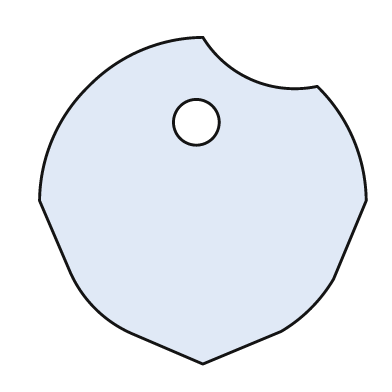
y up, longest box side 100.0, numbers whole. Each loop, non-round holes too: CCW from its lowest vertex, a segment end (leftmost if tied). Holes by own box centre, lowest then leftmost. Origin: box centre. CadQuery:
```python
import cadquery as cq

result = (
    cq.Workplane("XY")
    .moveTo(0.0, -50.0)
    .lineTo(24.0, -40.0)
    .threePointArc((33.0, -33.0), (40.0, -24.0))
    .lineTo(50.0, 0.0)
    .threePointArc((46.0, 19.0), (35.0, 35.0))
    .threePointArc((15.0, 37.0), (0.0, 50.0))
    .threePointArc((-19.0, 46.0), (-35.0, 35.0))
    .threePointArc((-46.0, 19.0), (-50.0, 0.0))
    .lineTo(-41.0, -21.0)
    .threePointArc((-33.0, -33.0), (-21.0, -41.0))
    .close()
    .moveTo(-2.0, 24.0)
    .circle(7.0)
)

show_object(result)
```